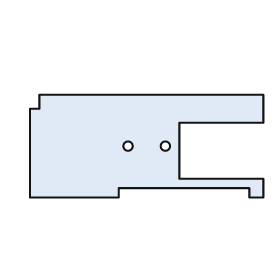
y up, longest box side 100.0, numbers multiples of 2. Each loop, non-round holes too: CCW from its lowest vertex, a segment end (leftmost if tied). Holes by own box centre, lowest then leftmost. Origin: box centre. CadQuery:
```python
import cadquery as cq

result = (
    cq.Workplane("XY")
    .moveTo(-50.0, -22.0)
    .lineTo(-12.0, -22.0)
    .lineTo(-12.0, -18.0)
    .lineTo(44.0, -18.0)
    .lineTo(44.0, -22.0)
    .lineTo(50.0, -22.0)
    .lineTo(50.0, -14.0)
    .lineTo(14.0, -14.0)
    .lineTo(14.0, 10.0)
    .lineTo(50.0, 10.0)
    .lineTo(50.0, 22.0)
    .lineTo(-46.0, 22.0)
    .lineTo(-46.0, 16.0)
    .lineTo(-50.0, 16.0)
    .close()
    .moveTo(-8.0, 0.0)
    .circle(2.0)
    .moveTo(8.0, 0.0)
    .circle(2.0)
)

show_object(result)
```